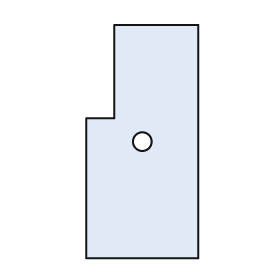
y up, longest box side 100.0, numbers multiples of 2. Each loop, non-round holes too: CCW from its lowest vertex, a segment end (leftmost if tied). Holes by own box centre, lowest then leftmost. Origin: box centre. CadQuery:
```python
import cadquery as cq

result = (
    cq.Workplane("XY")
    .moveTo(-24.0, -50.0)
    .lineTo(24.0, -50.0)
    .lineTo(24.0, 50.0)
    .lineTo(-12.0, 50.0)
    .lineTo(-12.0, 10.0)
    .lineTo(-24.0, 10.0)
    .close()
    .moveTo(0.0, 0.0)
    .circle(4.0)
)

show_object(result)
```